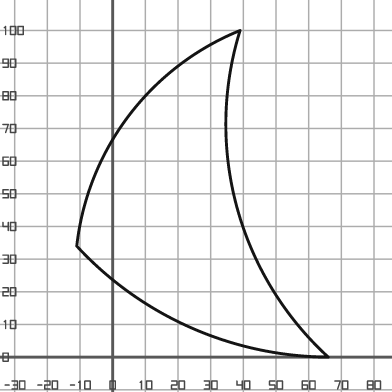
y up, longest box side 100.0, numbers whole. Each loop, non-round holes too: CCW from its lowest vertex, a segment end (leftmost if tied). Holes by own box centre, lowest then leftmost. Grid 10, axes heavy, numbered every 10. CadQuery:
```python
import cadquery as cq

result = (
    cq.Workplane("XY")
    .moveTo(66.0, 0.0)
    .threePointArc((38.0, 46.0), (39.0, 100.0))
    .threePointArc((5.0, 74.0), (-11.0, 34.0))
    .threePointArc((24.0, 9.0), (66.0, 0.0))
    .close()
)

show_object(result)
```